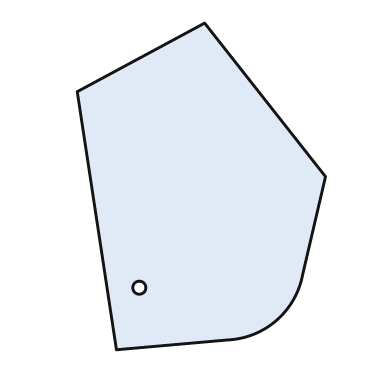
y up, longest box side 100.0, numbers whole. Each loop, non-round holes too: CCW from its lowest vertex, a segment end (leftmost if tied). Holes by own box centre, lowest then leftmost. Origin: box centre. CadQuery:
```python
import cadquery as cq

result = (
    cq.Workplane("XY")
    .moveTo(-26.0, -50.0)
    .lineTo(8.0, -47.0)
    .threePointArc((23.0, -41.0), (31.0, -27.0))
    .lineTo(38.0, 3.0)
    .lineTo(1.0, 50.0)
    .lineTo(-38.0, 29.0)
    .close()
    .moveTo(-19.0, -31.0)
    .circle(2.0)
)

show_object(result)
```